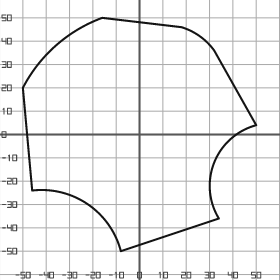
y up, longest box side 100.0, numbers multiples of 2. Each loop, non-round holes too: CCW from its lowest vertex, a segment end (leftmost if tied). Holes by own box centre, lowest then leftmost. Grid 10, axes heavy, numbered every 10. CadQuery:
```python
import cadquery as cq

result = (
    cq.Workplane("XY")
    .moveTo(-8.0, -50.0)
    .lineTo(34.0, -36.0)
    .threePointArc((32.0, -12.0), (50.0, 4.0))
    .lineTo(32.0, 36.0)
    .threePointArc((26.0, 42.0), (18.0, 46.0))
    .lineTo(-16.0, 50.0)
    .threePointArc((-36.0, 38.0), (-50.0, 20.0))
    .lineTo(-46.0, -24.0)
    .threePointArc((-22.0, -30.0), (-8.0, -50.0))
    .close()
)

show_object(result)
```